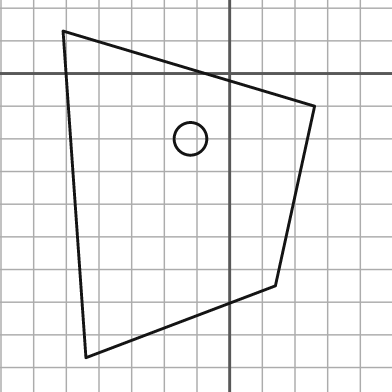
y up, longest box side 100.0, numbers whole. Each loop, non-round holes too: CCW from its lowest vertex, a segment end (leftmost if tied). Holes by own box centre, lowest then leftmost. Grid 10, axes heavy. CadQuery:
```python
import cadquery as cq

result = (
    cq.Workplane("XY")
    .moveTo(-44.0, -87.0)
    .lineTo(14.0, -65.0)
    .lineTo(26.0, -10.0)
    .lineTo(-51.0, 13.0)
    .close()
    .moveTo(-12.0, -20.0)
    .circle(5.0)
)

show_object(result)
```